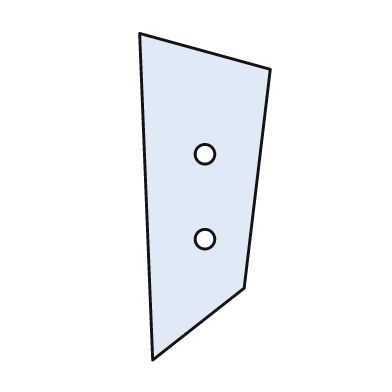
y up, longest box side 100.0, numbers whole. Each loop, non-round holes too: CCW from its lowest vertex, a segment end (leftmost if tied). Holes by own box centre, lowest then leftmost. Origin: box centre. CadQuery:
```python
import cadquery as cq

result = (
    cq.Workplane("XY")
    .moveTo(-16.0, -50.0)
    .lineTo(12.0, -28.0)
    .lineTo(20.0, 39.0)
    .lineTo(-20.0, 50.0)
    .close()
    .moveTo(0.0, -13.0)
    .circle(3.0)
    .moveTo(0.0, 13.0)
    .circle(3.0)
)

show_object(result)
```